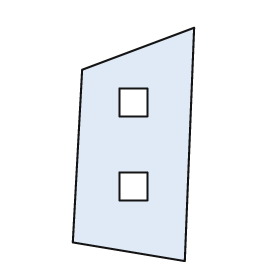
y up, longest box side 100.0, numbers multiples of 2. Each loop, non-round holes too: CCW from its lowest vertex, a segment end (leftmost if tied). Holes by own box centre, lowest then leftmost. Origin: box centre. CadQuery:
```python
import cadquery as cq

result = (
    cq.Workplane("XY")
    .moveTo(22.0, -50.0)
    .lineTo(26.0, 50.0)
    .lineTo(-22.0, 32.0)
    .lineTo(-26.0, -42.0)
    .close()
    .moveTo(-6.0, -24.0)
    .lineTo(6.0, -24.0)
    .lineTo(6.0, -12.0)
    .lineTo(-6.0, -12.0)
    .close()
    .moveTo(-6.0, 12.0)
    .lineTo(6.0, 12.0)
    .lineTo(6.0, 24.0)
    .lineTo(-6.0, 24.0)
    .close()
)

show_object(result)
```